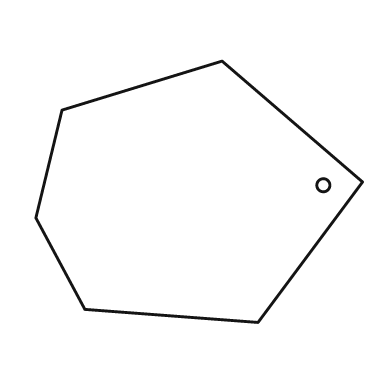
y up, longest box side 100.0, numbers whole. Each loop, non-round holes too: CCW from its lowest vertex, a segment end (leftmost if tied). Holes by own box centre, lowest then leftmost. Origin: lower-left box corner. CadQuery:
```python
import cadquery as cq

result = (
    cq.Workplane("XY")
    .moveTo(68.0, 0.0)
    .lineTo(100.0, 43.0)
    .lineTo(57.0, 80.0)
    .lineTo(8.0, 65.0)
    .lineTo(0.0, 32.0)
    .lineTo(15.0, 4.0)
    .close()
    .moveTo(88.0, 42.0)
    .circle(2.0)
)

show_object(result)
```